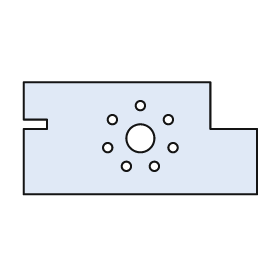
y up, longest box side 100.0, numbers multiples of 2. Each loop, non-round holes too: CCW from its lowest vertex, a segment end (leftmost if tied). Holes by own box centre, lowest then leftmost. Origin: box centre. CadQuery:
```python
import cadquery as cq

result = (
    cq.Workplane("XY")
    .moveTo(-50.0, -24.0)
    .lineTo(50.0, -24.0)
    .lineTo(50.0, 4.0)
    .lineTo(30.0, 4.0)
    .lineTo(30.0, 24.0)
    .lineTo(-50.0, 24.0)
    .lineTo(-50.0, 8.0)
    .lineTo(-40.0, 8.0)
    .lineTo(-40.0, 4.0)
    .lineTo(-50.0, 4.0)
    .close()
    .moveTo(-6.0, -12.0)
    .circle(2.0)
    .moveTo(6.0, -12.0)
    .circle(2.0)
    .moveTo(-14.0, -4.0)
    .circle(2.0)
    .moveTo(14.0, -4.0)
    .circle(2.0)
    .moveTo(0.0, 0.0)
    .circle(6.0)
    .moveTo(-12.0, 8.0)
    .circle(2.0)
    .moveTo(12.0, 8.0)
    .circle(2.0)
    .moveTo(0.0, 14.0)
    .circle(2.0)
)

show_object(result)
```